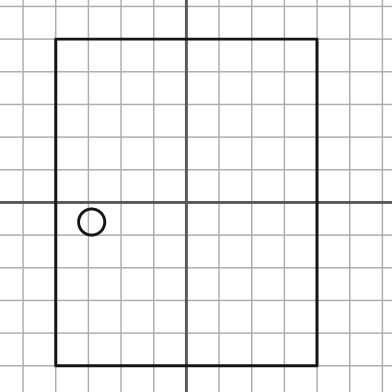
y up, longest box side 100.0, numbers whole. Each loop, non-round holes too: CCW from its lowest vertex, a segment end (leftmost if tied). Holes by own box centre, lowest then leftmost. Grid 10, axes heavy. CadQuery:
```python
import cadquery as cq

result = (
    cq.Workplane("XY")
    .moveTo(-40.0, -50.0)
    .lineTo(40.0, -50.0)
    .lineTo(40.0, 50.0)
    .lineTo(-40.0, 50.0)
    .close()
    .moveTo(-29.0, -6.0)
    .circle(4.0)
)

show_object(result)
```